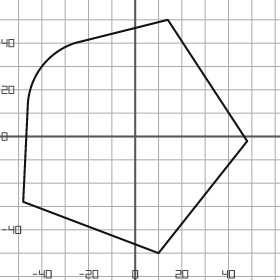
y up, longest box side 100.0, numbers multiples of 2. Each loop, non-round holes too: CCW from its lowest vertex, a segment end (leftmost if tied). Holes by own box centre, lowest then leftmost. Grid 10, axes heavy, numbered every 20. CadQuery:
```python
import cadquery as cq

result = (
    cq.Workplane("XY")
    .moveTo(10.0, -50.0)
    .lineTo(48.0, -2.0)
    .lineTo(14.0, 50.0)
    .lineTo(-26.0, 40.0)
    .threePointArc((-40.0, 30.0), (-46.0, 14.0))
    .lineTo(-48.0, -28.0)
    .close()
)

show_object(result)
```